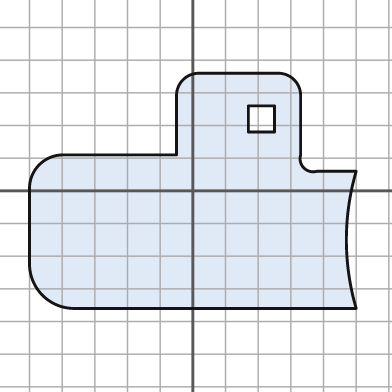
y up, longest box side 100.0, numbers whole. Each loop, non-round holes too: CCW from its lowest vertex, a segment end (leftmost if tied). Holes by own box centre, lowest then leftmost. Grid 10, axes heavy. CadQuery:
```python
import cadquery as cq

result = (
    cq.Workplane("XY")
    .moveTo(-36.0, -36.0)
    .lineTo(50.0, -36.0)
    .threePointArc((47.0, -15.0), (50.0, 6.0))
    .lineTo(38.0, 6.0)
    .threePointArc((34.0, 7.0), (33.0, 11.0))
    .lineTo(33.0, 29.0)
    .threePointArc((31.0, 34.0), (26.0, 36.0))
    .lineTo(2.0, 36.0)
    .threePointArc((-3.0, 34.0), (-5.0, 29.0))
    .lineTo(-5.0, 11.0)
    .lineTo(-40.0, 11.0)
    .threePointArc((-47.0, 8.0), (-50.0, 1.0))
    .lineTo(-50.0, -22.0)
    .threePointArc((-46.0, -32.0), (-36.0, -36.0))
    .close()
    .moveTo(17.0, 18.0)
    .lineTo(25.0, 18.0)
    .lineTo(25.0, 26.0)
    .lineTo(17.0, 26.0)
    .close()
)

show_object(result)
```